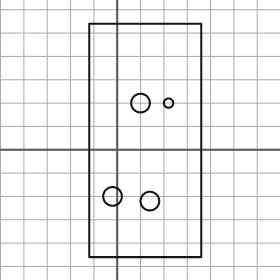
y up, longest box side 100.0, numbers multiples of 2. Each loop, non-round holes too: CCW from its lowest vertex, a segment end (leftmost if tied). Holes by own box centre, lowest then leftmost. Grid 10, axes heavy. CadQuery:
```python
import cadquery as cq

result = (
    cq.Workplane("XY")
    .moveTo(-12.0, -46.0)
    .lineTo(36.0, -46.0)
    .lineTo(36.0, 54.0)
    .lineTo(-12.0, 54.0)
    .close()
    .moveTo(14.0, -22.0)
    .circle(4.0)
    .moveTo(-2.0, -20.0)
    .circle(4.0)
    .moveTo(10.0, 20.0)
    .circle(4.0)
    .moveTo(22.0, 20.0)
    .circle(2.0)
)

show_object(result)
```